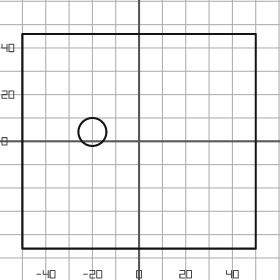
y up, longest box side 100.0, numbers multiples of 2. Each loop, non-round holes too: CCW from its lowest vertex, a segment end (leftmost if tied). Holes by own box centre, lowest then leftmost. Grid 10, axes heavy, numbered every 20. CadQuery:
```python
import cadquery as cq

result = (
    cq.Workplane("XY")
    .moveTo(-50.0, -46.0)
    .lineTo(50.0, -46.0)
    .lineTo(50.0, 46.0)
    .lineTo(-50.0, 46.0)
    .close()
    .moveTo(-20.0, 4.0)
    .circle(6.0)
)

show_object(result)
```